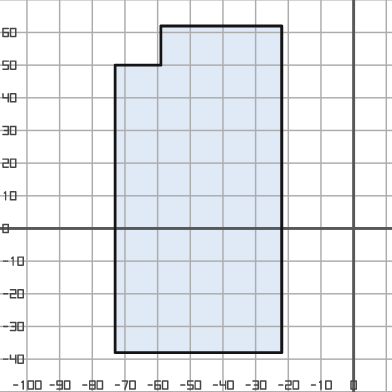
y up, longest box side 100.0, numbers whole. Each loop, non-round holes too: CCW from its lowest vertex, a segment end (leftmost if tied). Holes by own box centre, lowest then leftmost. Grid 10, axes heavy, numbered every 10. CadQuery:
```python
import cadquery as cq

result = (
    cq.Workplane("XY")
    .moveTo(-73.0, -38.0)
    .lineTo(-22.0, -38.0)
    .lineTo(-22.0, 62.0)
    .lineTo(-59.0, 62.0)
    .lineTo(-59.0, 50.0)
    .lineTo(-73.0, 50.0)
    .close()
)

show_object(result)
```